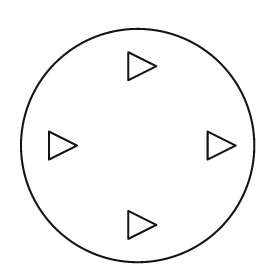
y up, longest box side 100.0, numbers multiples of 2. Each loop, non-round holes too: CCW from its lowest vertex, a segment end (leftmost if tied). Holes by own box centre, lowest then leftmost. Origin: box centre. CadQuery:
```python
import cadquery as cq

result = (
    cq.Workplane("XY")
    .moveTo(0.0, 0.0)
    .circle(50.0)
    .moveTo(-4.0, -40.0)
    .lineTo(8.0, -34.0)
    .lineTo(-4.0, -28.0)
    .close()
    .moveTo(-38.0, -6.0)
    .lineTo(-26.0, 0.0)
    .lineTo(-38.0, 6.0)
    .close()
    .moveTo(30.0, -6.0)
    .lineTo(42.0, 0.0)
    .lineTo(30.0, 6.0)
    .close()
    .moveTo(-4.0, 28.0)
    .lineTo(8.0, 34.0)
    .lineTo(-4.0, 40.0)
    .close()
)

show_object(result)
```